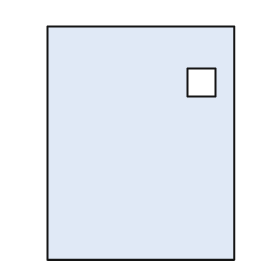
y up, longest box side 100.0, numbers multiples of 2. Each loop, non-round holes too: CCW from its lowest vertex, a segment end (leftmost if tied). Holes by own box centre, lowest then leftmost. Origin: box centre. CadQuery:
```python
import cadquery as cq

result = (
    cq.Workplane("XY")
    .moveTo(-40.0, -50.0)
    .lineTo(40.0, -50.0)
    .lineTo(40.0, 50.0)
    .lineTo(-40.0, 50.0)
    .close()
    .moveTo(20.0, 20.0)
    .lineTo(32.0, 20.0)
    .lineTo(32.0, 32.0)
    .lineTo(20.0, 32.0)
    .close()
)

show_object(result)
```